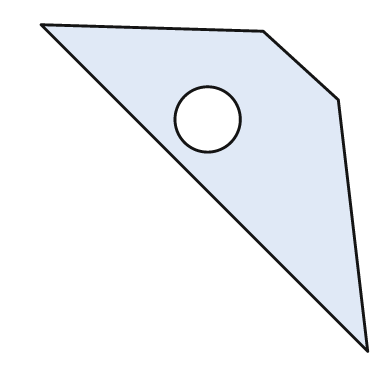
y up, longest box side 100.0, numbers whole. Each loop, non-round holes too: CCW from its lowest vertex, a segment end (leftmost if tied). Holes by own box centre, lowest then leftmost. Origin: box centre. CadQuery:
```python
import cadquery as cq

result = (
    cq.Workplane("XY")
    .moveTo(50.0, -50.0)
    .lineTo(41.0, 27.0)
    .lineTo(18.0, 48.0)
    .lineTo(-50.0, 50.0)
    .close()
    .moveTo(1.0, 21.0)
    .circle(10.0)
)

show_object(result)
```